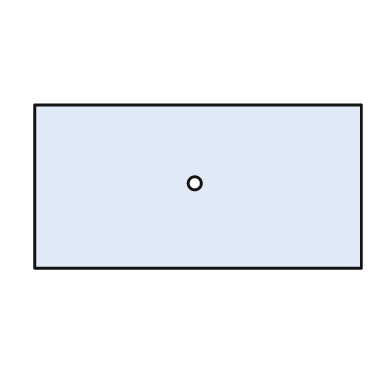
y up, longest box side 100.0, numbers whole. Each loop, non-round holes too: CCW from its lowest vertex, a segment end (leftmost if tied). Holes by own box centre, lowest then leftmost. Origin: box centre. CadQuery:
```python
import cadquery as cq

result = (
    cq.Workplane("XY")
    .moveTo(-50.0, -25.0)
    .lineTo(50.0, -25.0)
    .lineTo(50.0, 25.0)
    .lineTo(-50.0, 25.0)
    .close()
    .moveTo(-1.0, 1.0)
    .circle(2.0)
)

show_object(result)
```